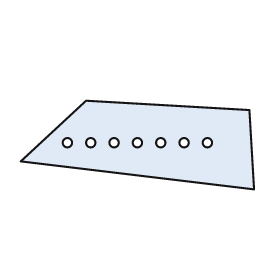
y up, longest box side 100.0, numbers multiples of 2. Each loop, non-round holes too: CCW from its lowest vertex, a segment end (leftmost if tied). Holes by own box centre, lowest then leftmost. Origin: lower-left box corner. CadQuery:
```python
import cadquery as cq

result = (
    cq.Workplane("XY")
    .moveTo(100.0, 0.0)
    .lineTo(98.0, 34.0)
    .lineTo(28.0, 38.0)
    .lineTo(0.0, 12.0)
    .close()
    .moveTo(20.0, 20.0)
    .circle(2.0)
    .moveTo(30.0, 20.0)
    .circle(2.0)
    .moveTo(40.0, 20.0)
    .circle(2.0)
    .moveTo(50.0, 20.0)
    .circle(2.0)
    .moveTo(60.0, 20.0)
    .circle(2.0)
    .moveTo(70.0, 20.0)
    .circle(2.0)
    .moveTo(80.0, 20.0)
    .circle(2.0)
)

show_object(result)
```